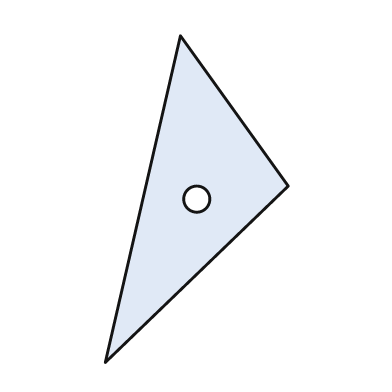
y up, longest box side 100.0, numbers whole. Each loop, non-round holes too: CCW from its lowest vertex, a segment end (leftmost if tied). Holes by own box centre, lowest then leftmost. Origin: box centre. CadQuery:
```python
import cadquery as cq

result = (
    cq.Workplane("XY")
    .moveTo(-28.0, -50.0)
    .lineTo(28.0, 4.0)
    .lineTo(-5.0, 50.0)
    .close()
    .moveTo(0.0, 0.0)
    .circle(4.0)
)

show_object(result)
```